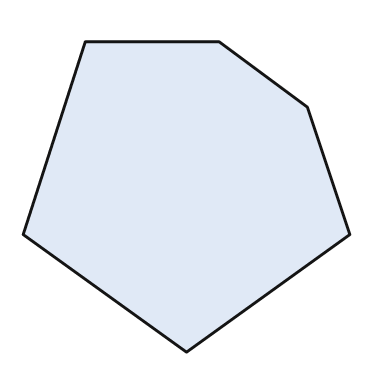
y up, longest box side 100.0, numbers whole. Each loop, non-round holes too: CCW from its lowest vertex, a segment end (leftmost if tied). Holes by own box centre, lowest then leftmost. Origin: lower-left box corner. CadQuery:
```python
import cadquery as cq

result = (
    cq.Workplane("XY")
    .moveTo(50.0, 0.0)
    .lineTo(100.0, 36.0)
    .lineTo(87.0, 75.0)
    .lineTo(60.0, 95.0)
    .lineTo(19.0, 95.0)
    .lineTo(0.0, 36.0)
    .close()
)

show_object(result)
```